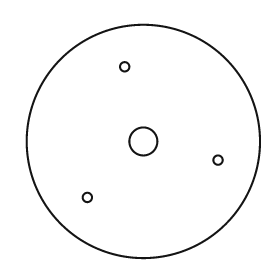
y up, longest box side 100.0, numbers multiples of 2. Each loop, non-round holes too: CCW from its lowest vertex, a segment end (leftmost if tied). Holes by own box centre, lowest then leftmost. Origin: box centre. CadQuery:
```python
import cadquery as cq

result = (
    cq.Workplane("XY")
    .moveTo(0.0, 0.0)
    .circle(50.0)
    .moveTo(-24.0, -24.0)
    .circle(2.0)
    .moveTo(32.0, -8.0)
    .circle(2.0)
    .moveTo(0.0, 0.0)
    .circle(6.0)
    .moveTo(-8.0, 32.0)
    .circle(2.0)
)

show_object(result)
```